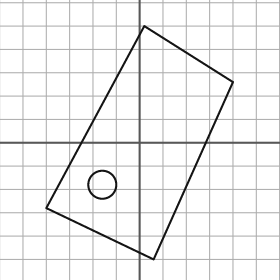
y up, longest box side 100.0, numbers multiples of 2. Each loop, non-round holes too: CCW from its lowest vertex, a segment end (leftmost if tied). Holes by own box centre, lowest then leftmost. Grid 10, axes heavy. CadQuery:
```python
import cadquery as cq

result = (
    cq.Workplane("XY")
    .moveTo(6.0, -50.0)
    .lineTo(40.0, 26.0)
    .lineTo(2.0, 50.0)
    .lineTo(-40.0, -28.0)
    .close()
    .moveTo(-16.0, -18.0)
    .circle(6.0)
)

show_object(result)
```